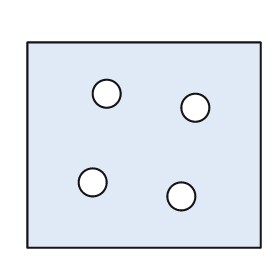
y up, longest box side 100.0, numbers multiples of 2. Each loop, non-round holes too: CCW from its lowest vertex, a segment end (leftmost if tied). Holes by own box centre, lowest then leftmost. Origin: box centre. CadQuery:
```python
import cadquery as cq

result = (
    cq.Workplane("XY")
    .moveTo(-50.0, -44.0)
    .lineTo(50.0, -44.0)
    .lineTo(50.0, 44.0)
    .lineTo(-50.0, 44.0)
    .close()
    .moveTo(16.0, -22.0)
    .circle(6.0)
    .moveTo(-22.0, -16.0)
    .circle(6.0)
    .moveTo(22.0, 16.0)
    .circle(6.0)
    .moveTo(-16.0, 22.0)
    .circle(6.0)
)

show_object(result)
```